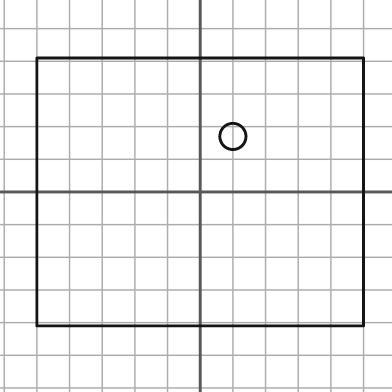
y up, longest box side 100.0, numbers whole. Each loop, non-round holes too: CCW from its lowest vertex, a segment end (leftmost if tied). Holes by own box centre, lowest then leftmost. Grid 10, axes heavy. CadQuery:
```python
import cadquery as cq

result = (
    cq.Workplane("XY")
    .moveTo(-50.0, -41.0)
    .lineTo(50.0, -41.0)
    .lineTo(50.0, 41.0)
    .lineTo(-50.0, 41.0)
    .close()
    .moveTo(10.0, 17.0)
    .circle(4.0)
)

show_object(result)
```